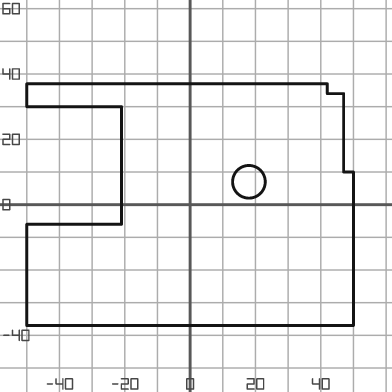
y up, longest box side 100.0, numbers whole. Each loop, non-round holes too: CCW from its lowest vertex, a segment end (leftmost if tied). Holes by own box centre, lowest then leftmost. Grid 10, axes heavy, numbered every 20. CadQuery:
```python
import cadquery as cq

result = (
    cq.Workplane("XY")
    .moveTo(-50.0, -37.0)
    .lineTo(50.0, -37.0)
    .lineTo(50.0, 10.0)
    .lineTo(47.0, 10.0)
    .lineTo(47.0, 34.0)
    .lineTo(42.0, 34.0)
    .lineTo(42.0, 37.0)
    .lineTo(-50.0, 37.0)
    .lineTo(-50.0, 30.0)
    .lineTo(-21.0, 30.0)
    .lineTo(-21.0, -6.0)
    .lineTo(-50.0, -6.0)
    .close()
    .moveTo(18.0, 7.0)
    .circle(5.0)
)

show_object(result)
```